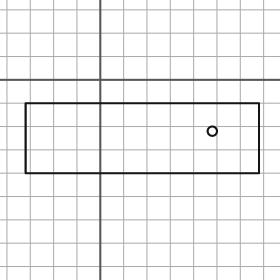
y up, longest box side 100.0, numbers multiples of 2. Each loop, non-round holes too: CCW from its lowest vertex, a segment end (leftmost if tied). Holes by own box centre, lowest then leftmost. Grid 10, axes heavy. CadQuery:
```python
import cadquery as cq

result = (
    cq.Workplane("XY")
    .moveTo(-32.0, -40.0)
    .lineTo(68.0, -40.0)
    .lineTo(68.0, -10.0)
    .lineTo(-32.0, -10.0)
    .close()
    .moveTo(48.0, -22.0)
    .circle(2.0)
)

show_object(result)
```